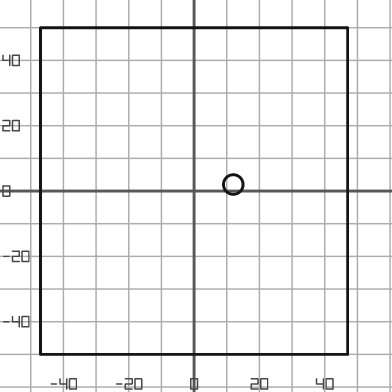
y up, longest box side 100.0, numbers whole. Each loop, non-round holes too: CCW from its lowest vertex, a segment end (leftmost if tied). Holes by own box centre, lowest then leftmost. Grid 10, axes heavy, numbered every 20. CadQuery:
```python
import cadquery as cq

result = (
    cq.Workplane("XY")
    .moveTo(-47.0, -50.0)
    .lineTo(47.0, -50.0)
    .lineTo(47.0, 50.0)
    .lineTo(-47.0, 50.0)
    .close()
    .moveTo(12.0, 2.0)
    .circle(3.0)
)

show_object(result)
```